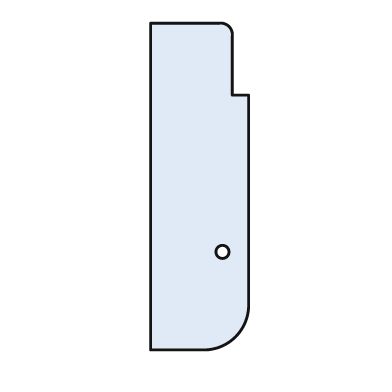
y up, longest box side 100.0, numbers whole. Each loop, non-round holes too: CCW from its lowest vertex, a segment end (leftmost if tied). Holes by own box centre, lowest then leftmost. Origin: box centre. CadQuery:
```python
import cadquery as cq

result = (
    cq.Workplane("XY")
    .moveTo(-15.0, -50.0)
    .lineTo(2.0, -50.0)
    .threePointArc((11.0, -46.0), (15.0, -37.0))
    .lineTo(15.0, 28.0)
    .lineTo(10.0, 28.0)
    .lineTo(10.0, 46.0)
    .threePointArc((9.0, 49.0), (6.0, 50.0))
    .lineTo(-15.0, 50.0)
    .close()
    .moveTo(7.0, -20.0)
    .circle(2.0)
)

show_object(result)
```